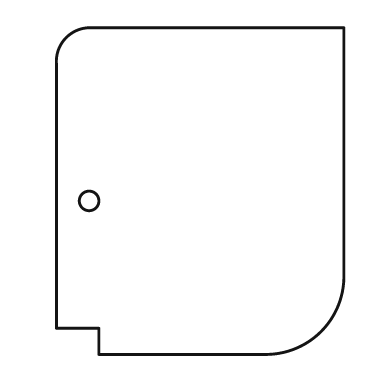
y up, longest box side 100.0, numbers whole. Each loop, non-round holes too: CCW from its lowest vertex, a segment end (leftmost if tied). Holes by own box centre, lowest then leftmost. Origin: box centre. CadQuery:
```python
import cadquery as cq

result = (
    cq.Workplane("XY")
    .moveTo(-31.0, -50.0)
    .lineTo(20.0, -50.0)
    .threePointArc((37.0, -43.0), (44.0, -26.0))
    .lineTo(44.0, 50.0)
    .lineTo(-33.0, 50.0)
    .threePointArc((-41.0, 47.0), (-44.0, 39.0))
    .lineTo(-44.0, -42.0)
    .lineTo(-31.0, -42.0)
    .close()
    .moveTo(-34.0, -3.0)
    .circle(3.0)
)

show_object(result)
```